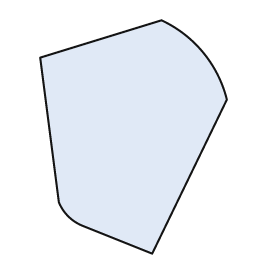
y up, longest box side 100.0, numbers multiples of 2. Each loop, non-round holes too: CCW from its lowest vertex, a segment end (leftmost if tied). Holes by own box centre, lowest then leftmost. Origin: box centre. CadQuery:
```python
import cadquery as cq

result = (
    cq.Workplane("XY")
    .moveTo(8.0, -50.0)
    .lineTo(40.0, 16.0)
    .threePointArc((30.0, 36.0), (12.0, 50.0))
    .lineTo(-40.0, 34.0)
    .lineTo(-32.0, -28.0)
    .threePointArc((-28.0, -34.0), (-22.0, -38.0))
    .close()
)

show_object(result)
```